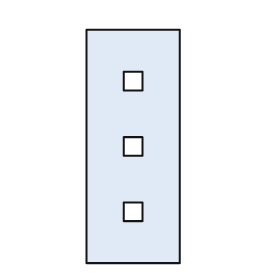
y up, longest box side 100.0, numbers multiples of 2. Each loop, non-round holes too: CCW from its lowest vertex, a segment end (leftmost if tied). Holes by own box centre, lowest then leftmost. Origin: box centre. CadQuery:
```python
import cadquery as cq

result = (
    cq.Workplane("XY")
    .moveTo(-20.0, -50.0)
    .lineTo(20.0, -50.0)
    .lineTo(20.0, 50.0)
    .lineTo(-20.0, 50.0)
    .close()
    .moveTo(-4.0, -32.0)
    .lineTo(4.0, -32.0)
    .lineTo(4.0, -24.0)
    .lineTo(-4.0, -24.0)
    .close()
    .moveTo(-4.0, -4.0)
    .lineTo(4.0, -4.0)
    .lineTo(4.0, 4.0)
    .lineTo(-4.0, 4.0)
    .close()
    .moveTo(-4.0, 24.0)
    .lineTo(4.0, 24.0)
    .lineTo(4.0, 32.0)
    .lineTo(-4.0, 32.0)
    .close()
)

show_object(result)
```